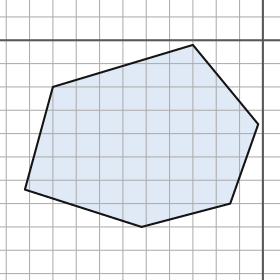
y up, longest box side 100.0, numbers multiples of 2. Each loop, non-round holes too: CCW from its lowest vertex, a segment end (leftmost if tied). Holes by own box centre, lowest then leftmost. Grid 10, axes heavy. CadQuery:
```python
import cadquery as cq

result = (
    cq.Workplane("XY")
    .moveTo(-52.0, -80.0)
    .lineTo(-14.0, -70.0)
    .lineTo(-2.0, -36.0)
    .lineTo(-30.0, -2.0)
    .lineTo(-90.0, -20.0)
    .lineTo(-102.0, -64.0)
    .close()
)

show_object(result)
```